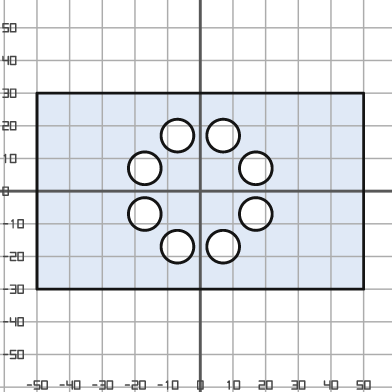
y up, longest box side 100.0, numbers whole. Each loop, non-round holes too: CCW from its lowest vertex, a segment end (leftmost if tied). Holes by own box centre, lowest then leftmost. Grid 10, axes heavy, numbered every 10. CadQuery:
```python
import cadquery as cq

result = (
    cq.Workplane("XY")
    .moveTo(-50.0, -30.0)
    .lineTo(50.0, -30.0)
    .lineTo(50.0, 30.0)
    .lineTo(-50.0, 30.0)
    .close()
    .moveTo(-7.0, -17.0)
    .circle(5.0)
    .moveTo(7.0, -17.0)
    .circle(5.0)
    .moveTo(-17.0, -7.0)
    .circle(5.0)
    .moveTo(17.0, -7.0)
    .circle(5.0)
    .moveTo(-17.0, 7.0)
    .circle(5.0)
    .moveTo(17.0, 7.0)
    .circle(5.0)
    .moveTo(-7.0, 17.0)
    .circle(5.0)
    .moveTo(7.0, 17.0)
    .circle(5.0)
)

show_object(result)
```